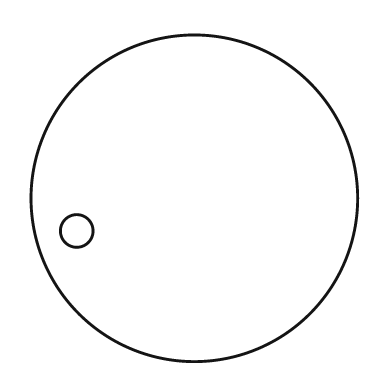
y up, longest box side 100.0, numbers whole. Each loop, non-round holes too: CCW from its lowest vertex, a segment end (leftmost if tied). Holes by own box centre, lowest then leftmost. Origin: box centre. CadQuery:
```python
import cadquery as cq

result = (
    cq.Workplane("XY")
    .moveTo(0.0, 0.0)
    .circle(50.0)
    .moveTo(-36.0, -10.0)
    .circle(5.0)
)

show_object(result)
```